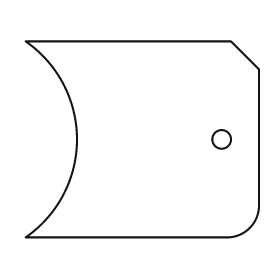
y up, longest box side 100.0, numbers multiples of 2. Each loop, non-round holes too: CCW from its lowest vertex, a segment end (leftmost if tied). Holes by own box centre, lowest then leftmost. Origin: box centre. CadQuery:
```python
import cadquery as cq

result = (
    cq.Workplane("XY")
    .moveTo(-50.0, -42.0)
    .lineTo(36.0, -42.0)
    .threePointArc((46.0, -38.0), (50.0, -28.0))
    .lineTo(50.0, 30.0)
    .lineTo(38.0, 42.0)
    .lineTo(-50.0, 42.0)
    .threePointArc((-28.0, 0.0), (-50.0, -42.0))
    .close()
    .moveTo(34.0, 0.0)
    .circle(4.0)
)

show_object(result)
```